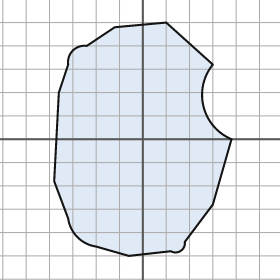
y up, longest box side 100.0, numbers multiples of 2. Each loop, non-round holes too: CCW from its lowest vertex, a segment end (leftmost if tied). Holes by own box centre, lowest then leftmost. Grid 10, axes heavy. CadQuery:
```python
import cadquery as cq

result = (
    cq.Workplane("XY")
    .moveTo(-6.0, -50.0)
    .lineTo(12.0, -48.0)
    .threePointArc((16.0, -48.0), (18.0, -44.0))
    .lineTo(30.0, -28.0)
    .lineTo(38.0, 0.0)
    .threePointArc((26.0, 14.0), (30.0, 32.0))
    .lineTo(10.0, 50.0)
    .lineTo(-12.0, 48.0)
    .lineTo(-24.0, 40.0)
    .threePointArc((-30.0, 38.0), (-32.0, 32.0))
    .lineTo(-36.0, 20.0)
    .lineTo(-38.0, -18.0)
    .lineTo(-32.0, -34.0)
    .threePointArc((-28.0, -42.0), (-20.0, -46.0))
    .close()
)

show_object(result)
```